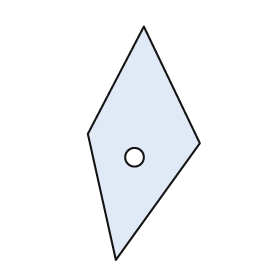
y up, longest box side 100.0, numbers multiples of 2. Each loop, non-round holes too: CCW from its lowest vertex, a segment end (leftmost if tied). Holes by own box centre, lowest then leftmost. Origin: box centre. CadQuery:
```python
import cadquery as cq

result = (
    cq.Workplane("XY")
    .moveTo(-12.0, -50.0)
    .lineTo(24.0, 0.0)
    .lineTo(0.0, 50.0)
    .lineTo(-24.0, 4.0)
    .close()
    .moveTo(-4.0, -6.0)
    .circle(4.0)
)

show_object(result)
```